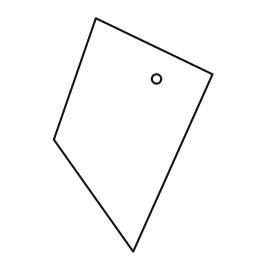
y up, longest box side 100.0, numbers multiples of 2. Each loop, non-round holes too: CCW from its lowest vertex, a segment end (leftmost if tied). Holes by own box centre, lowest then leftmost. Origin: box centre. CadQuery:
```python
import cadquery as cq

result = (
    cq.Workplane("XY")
    .moveTo(0.0, -50.0)
    .lineTo(34.0, 26.0)
    .lineTo(-16.0, 50.0)
    .lineTo(-34.0, -2.0)
    .close()
    .moveTo(10.0, 24.0)
    .circle(2.0)
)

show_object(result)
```